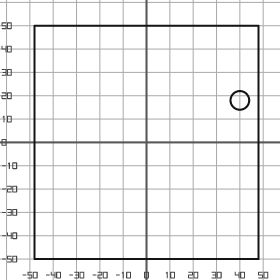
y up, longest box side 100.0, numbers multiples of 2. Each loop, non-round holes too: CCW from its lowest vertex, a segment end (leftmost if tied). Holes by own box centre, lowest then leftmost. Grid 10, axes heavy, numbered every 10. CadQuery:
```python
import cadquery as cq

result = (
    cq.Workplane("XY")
    .moveTo(-48.0, -50.0)
    .lineTo(48.0, -50.0)
    .lineTo(48.0, 50.0)
    .lineTo(-48.0, 50.0)
    .close()
    .moveTo(40.0, 18.0)
    .circle(4.0)
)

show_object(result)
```